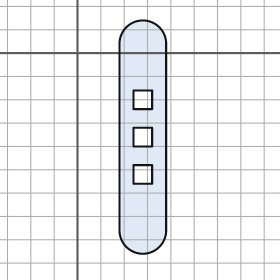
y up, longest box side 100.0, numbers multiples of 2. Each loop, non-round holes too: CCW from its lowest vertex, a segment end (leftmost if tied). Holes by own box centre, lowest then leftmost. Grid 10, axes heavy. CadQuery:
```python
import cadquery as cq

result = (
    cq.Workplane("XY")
    .moveTo(18.0, -76.0)
    .threePointArc((28.0, -86.0), (38.0, -76.0))
    .lineTo(38.0, 4.0)
    .threePointArc((28.0, 14.0), (18.0, 4.0))
    .close()
    .moveTo(24.0, -56.0)
    .lineTo(32.0, -56.0)
    .lineTo(32.0, -48.0)
    .lineTo(24.0, -48.0)
    .close()
    .moveTo(24.0, -40.0)
    .lineTo(32.0, -40.0)
    .lineTo(32.0, -32.0)
    .lineTo(24.0, -32.0)
    .close()
    .moveTo(24.0, -24.0)
    .lineTo(32.0, -24.0)
    .lineTo(32.0, -16.0)
    .lineTo(24.0, -16.0)
    .close()
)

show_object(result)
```